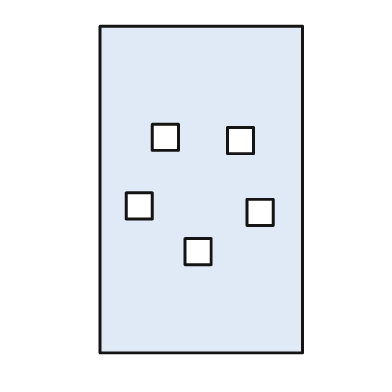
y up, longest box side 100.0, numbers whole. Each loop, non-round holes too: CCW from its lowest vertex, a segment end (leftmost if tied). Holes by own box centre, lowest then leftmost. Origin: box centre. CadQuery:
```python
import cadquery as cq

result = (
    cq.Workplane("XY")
    .moveTo(-31.0, -50.0)
    .lineTo(31.0, -50.0)
    .lineTo(31.0, 50.0)
    .lineTo(-31.0, 50.0)
    .close()
    .moveTo(-5.0, -23.0)
    .lineTo(3.0, -23.0)
    .lineTo(3.0, -15.0)
    .lineTo(-5.0, -15.0)
    .close()
    .moveTo(14.0, -11.0)
    .lineTo(22.0, -11.0)
    .lineTo(22.0, -3.0)
    .lineTo(14.0, -3.0)
    .close()
    .moveTo(-23.0, -9.0)
    .lineTo(-15.0, -9.0)
    .lineTo(-15.0, -1.0)
    .lineTo(-23.0, -1.0)
    .close()
    .moveTo(8.0, 11.0)
    .lineTo(16.0, 11.0)
    .lineTo(16.0, 19.0)
    .lineTo(8.0, 19.0)
    .close()
    .moveTo(-15.0, 12.0)
    .lineTo(-7.0, 12.0)
    .lineTo(-7.0, 20.0)
    .lineTo(-15.0, 20.0)
    .close()
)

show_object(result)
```